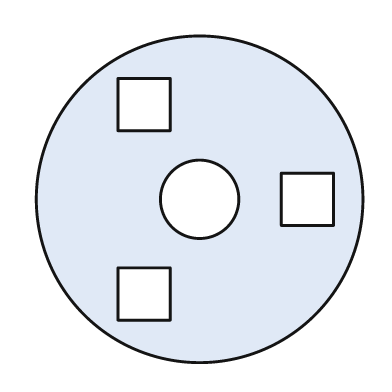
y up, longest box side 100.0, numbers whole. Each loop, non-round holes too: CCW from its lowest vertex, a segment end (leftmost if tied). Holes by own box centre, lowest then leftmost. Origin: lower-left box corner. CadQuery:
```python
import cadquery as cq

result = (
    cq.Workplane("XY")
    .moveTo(50.0, 50.0)
    .circle(50.0)
    .moveTo(25.0, 13.0)
    .lineTo(41.0, 13.0)
    .lineTo(41.0, 29.0)
    .lineTo(25.0, 29.0)
    .close()
    .moveTo(50.0, 50.0)
    .circle(12.0)
    .moveTo(75.0, 42.0)
    .lineTo(91.0, 42.0)
    .lineTo(91.0, 58.0)
    .lineTo(75.0, 58.0)
    .close()
    .moveTo(25.0, 71.0)
    .lineTo(41.0, 71.0)
    .lineTo(41.0, 87.0)
    .lineTo(25.0, 87.0)
    .close()
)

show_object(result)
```